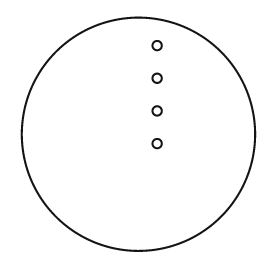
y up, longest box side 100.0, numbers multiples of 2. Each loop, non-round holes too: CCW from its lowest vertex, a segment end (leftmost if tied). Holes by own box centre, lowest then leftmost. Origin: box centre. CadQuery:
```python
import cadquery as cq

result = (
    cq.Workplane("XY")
    .moveTo(0.0, 0.0)
    .circle(50.0)
    .moveTo(8.0, -4.0)
    .circle(2.0)
    .moveTo(8.0, 10.0)
    .circle(2.0)
    .moveTo(8.0, 24.0)
    .circle(2.0)
    .moveTo(8.0, 38.0)
    .circle(2.0)
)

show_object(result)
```